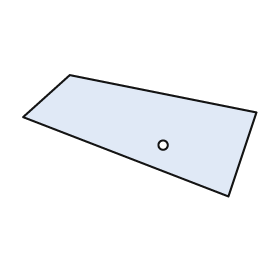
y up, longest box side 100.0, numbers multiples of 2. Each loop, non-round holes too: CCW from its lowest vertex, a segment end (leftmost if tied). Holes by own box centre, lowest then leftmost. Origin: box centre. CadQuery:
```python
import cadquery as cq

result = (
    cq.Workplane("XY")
    .moveTo(38.0, -26.0)
    .lineTo(50.0, 10.0)
    .lineTo(-30.0, 26.0)
    .lineTo(-50.0, 8.0)
    .close()
    .moveTo(10.0, -4.0)
    .circle(2.0)
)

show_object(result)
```